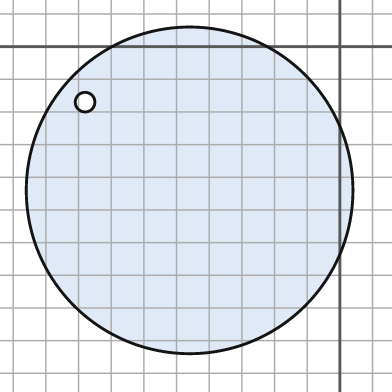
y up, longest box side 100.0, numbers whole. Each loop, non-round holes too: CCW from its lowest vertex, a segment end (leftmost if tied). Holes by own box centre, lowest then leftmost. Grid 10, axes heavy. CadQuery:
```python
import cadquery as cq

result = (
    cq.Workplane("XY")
    .moveTo(-46.0, -44.0)
    .circle(50.0)
    .moveTo(-78.0, -17.0)
    .circle(3.0)
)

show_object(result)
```